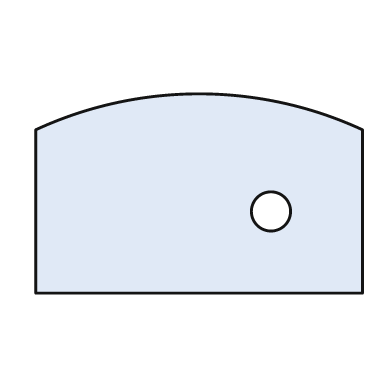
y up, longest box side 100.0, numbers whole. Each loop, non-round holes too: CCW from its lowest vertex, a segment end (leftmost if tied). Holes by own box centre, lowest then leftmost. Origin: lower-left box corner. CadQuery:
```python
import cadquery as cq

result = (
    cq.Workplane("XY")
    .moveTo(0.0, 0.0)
    .lineTo(100.0, 0.0)
    .lineTo(100.0, 50.0)
    .threePointArc((50.0, 61.0), (0.0, 50.0))
    .close()
    .moveTo(72.0, 25.0)
    .circle(6.0)
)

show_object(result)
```